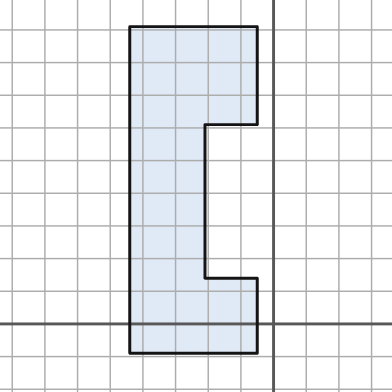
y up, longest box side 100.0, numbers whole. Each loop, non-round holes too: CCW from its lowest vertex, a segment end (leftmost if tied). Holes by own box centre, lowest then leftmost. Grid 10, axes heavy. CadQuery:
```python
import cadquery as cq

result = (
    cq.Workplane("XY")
    .moveTo(-44.0, -9.0)
    .lineTo(-5.0, -9.0)
    .lineTo(-5.0, 14.0)
    .lineTo(-21.0, 14.0)
    .lineTo(-21.0, 61.0)
    .lineTo(-5.0, 61.0)
    .lineTo(-5.0, 91.0)
    .lineTo(-44.0, 91.0)
    .close()
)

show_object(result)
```